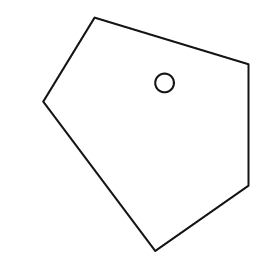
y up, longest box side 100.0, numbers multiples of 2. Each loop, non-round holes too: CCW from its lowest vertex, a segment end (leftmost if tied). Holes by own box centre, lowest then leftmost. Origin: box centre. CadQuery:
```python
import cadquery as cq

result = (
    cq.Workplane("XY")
    .moveTo(4.0, -50.0)
    .lineTo(44.0, -22.0)
    .lineTo(44.0, 30.0)
    .lineTo(-22.0, 50.0)
    .lineTo(-44.0, 14.0)
    .close()
    .moveTo(8.0, 22.0)
    .circle(4.0)
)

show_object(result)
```